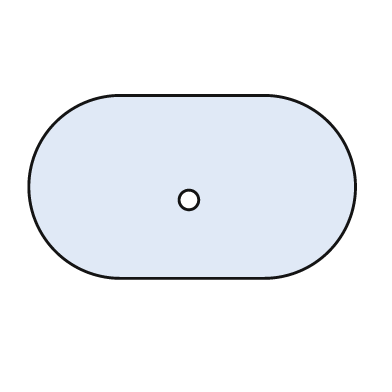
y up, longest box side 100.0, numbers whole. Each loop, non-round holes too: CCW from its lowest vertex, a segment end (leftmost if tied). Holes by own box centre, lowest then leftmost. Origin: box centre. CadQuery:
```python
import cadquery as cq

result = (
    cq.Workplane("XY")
    .moveTo(-22.0, -28.0)
    .lineTo(22.0, -28.0)
    .threePointArc((50.0, 0.0), (22.0, 28.0))
    .lineTo(-22.0, 28.0)
    .threePointArc((-50.0, 0.0), (-22.0, -28.0))
    .close()
    .moveTo(-1.0, -4.0)
    .circle(3.0)
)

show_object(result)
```